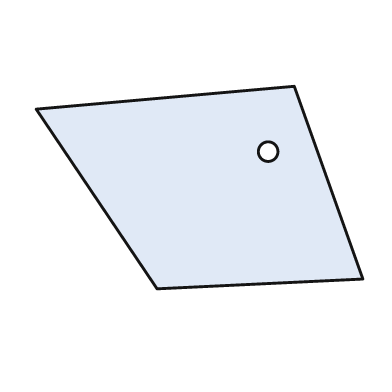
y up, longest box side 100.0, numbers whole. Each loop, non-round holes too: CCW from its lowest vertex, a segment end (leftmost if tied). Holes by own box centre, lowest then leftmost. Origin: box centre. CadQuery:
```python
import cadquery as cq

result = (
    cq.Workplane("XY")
    .moveTo(-13.0, -31.0)
    .lineTo(50.0, -28.0)
    .lineTo(29.0, 31.0)
    .lineTo(-50.0, 24.0)
    .close()
    .moveTo(21.0, 11.0)
    .circle(3.0)
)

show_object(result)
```